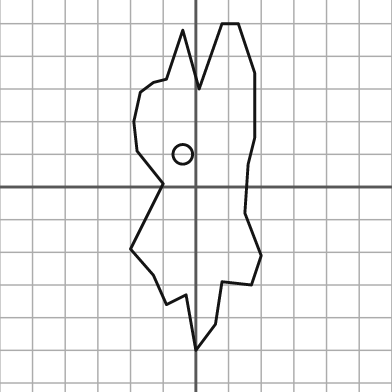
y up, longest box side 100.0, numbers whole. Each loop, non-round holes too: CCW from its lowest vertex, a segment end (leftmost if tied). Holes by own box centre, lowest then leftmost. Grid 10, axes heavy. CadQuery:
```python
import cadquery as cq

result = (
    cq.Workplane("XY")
    .moveTo(0.0, -50.0)
    .lineTo(6.0, -42.0)
    .lineTo(8.0, -29.0)
    .lineTo(17.0, -30.0)
    .lineTo(20.0, -21.0)
    .lineTo(15.0, -8.0)
    .lineTo(16.0, 7.0)
    .lineTo(18.0, 15.0)
    .lineTo(18.0, 35.0)
    .lineTo(13.0, 50.0)
    .lineTo(8.0, 50.0)
    .lineTo(1.0, 30.0)
    .lineTo(-4.0, 48.0)
    .lineTo(-9.0, 33.0)
    .lineTo(-13.0, 32.0)
    .lineTo(-17.0, 29.0)
    .lineTo(-19.0, 20.0)
    .lineTo(-18.0, 11.0)
    .lineTo(-10.0, 1.0)
    .lineTo(-20.0, -19.0)
    .lineTo(-13.0, -27.0)
    .lineTo(-9.0, -36.0)
    .lineTo(-3.0, -33.0)
    .close()
    .moveTo(-4.0, 10.0)
    .circle(3.0)
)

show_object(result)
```